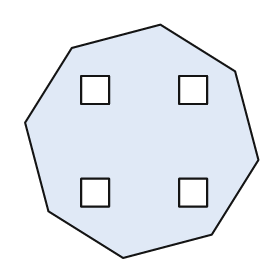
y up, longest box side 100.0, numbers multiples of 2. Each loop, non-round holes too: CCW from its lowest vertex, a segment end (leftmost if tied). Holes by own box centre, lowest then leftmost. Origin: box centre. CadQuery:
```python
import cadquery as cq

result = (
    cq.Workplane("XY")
    .moveTo(-8.0, -50.0)
    .lineTo(30.0, -40.0)
    .lineTo(50.0, -8.0)
    .lineTo(40.0, 30.0)
    .lineTo(8.0, 50.0)
    .lineTo(-30.0, 40.0)
    .lineTo(-50.0, 8.0)
    .lineTo(-40.0, -30.0)
    .close()
    .moveTo(-26.0, -28.0)
    .lineTo(-14.0, -28.0)
    .lineTo(-14.0, -16.0)
    .lineTo(-26.0, -16.0)
    .close()
    .moveTo(16.0, -28.0)
    .lineTo(28.0, -28.0)
    .lineTo(28.0, -16.0)
    .lineTo(16.0, -16.0)
    .close()
    .moveTo(-26.0, 16.0)
    .lineTo(-14.0, 16.0)
    .lineTo(-14.0, 28.0)
    .lineTo(-26.0, 28.0)
    .close()
    .moveTo(16.0, 16.0)
    .lineTo(28.0, 16.0)
    .lineTo(28.0, 28.0)
    .lineTo(16.0, 28.0)
    .close()
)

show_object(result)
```